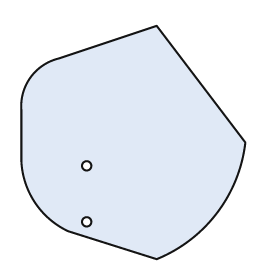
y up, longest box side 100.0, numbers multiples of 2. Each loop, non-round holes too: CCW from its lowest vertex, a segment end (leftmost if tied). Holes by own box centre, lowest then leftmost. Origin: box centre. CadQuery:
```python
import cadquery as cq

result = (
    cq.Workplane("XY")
    .moveTo(10.0, -50.0)
    .threePointArc((36.0, -30.0), (48.0, 0.0))
    .lineTo(10.0, 50.0)
    .lineTo(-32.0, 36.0)
    .threePointArc((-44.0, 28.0), (-48.0, 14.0))
    .lineTo(-48.0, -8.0)
    .threePointArc((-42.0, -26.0), (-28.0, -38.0))
    .close()
    .moveTo(-20.0, -34.0)
    .circle(2.0)
    .moveTo(-20.0, -10.0)
    .circle(2.0)
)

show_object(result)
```